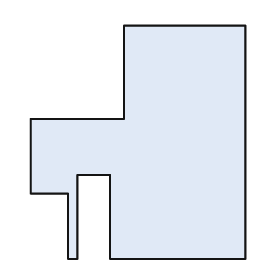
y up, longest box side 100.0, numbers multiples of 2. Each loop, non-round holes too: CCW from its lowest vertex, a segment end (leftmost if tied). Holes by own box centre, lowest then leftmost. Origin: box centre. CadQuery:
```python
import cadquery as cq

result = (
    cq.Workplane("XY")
    .moveTo(-30.0, -50.0)
    .lineTo(-26.0, -50.0)
    .lineTo(-26.0, -14.0)
    .lineTo(-12.0, -14.0)
    .lineTo(-12.0, -50.0)
    .lineTo(46.0, -50.0)
    .lineTo(46.0, 50.0)
    .lineTo(-6.0, 50.0)
    .lineTo(-6.0, 10.0)
    .lineTo(-46.0, 10.0)
    .lineTo(-46.0, -22.0)
    .lineTo(-30.0, -22.0)
    .close()
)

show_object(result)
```